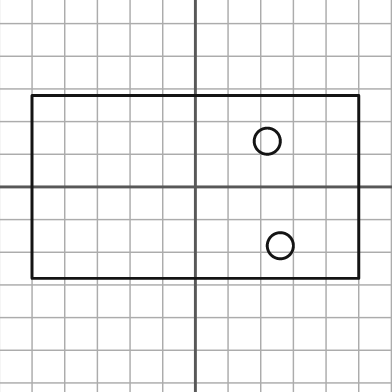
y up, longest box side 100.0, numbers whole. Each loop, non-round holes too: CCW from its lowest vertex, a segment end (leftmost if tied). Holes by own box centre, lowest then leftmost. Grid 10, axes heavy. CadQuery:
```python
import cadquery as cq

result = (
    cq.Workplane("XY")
    .moveTo(-50.0, -28.0)
    .lineTo(50.0, -28.0)
    .lineTo(50.0, 28.0)
    .lineTo(-50.0, 28.0)
    .close()
    .moveTo(26.0, -18.0)
    .circle(4.0)
    .moveTo(22.0, 14.0)
    .circle(4.0)
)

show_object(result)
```